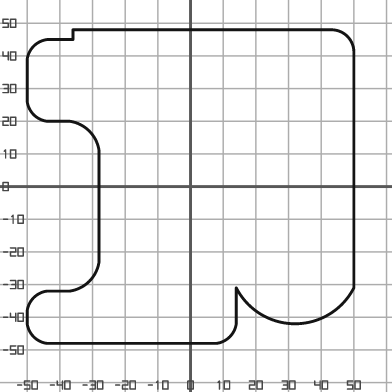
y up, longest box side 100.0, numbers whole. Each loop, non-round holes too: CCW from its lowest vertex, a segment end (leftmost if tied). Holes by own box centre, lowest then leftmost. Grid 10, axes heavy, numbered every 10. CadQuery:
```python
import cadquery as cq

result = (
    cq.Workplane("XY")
    .moveTo(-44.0, -48.0)
    .lineTo(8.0, -48.0)
    .threePointArc((12.0, -46.0), (14.0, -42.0))
    .lineTo(14.0, -31.0)
    .threePointArc((32.0, -42.0), (50.0, -31.0))
    .lineTo(50.0, 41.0)
    .threePointArc((48.0, 46.0), (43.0, 48.0))
    .lineTo(-36.0, 48.0)
    .lineTo(-36.0, 45.0)
    .lineTo(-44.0, 45.0)
    .threePointArc((-48.0, 43.0), (-50.0, 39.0))
    .lineTo(-50.0, 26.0)
    .threePointArc((-48.0, 22.0), (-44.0, 20.0))
    .lineTo(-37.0, 20.0)
    .threePointArc((-31.0, 17.0), (-28.0, 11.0))
    .lineTo(-28.0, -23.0)
    .threePointArc((-31.0, -29.0), (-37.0, -32.0))
    .lineTo(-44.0, -32.0)
    .threePointArc((-48.0, -34.0), (-50.0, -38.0))
    .lineTo(-50.0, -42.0)
    .threePointArc((-48.0, -46.0), (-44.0, -48.0))
    .close()
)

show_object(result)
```